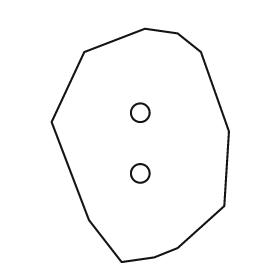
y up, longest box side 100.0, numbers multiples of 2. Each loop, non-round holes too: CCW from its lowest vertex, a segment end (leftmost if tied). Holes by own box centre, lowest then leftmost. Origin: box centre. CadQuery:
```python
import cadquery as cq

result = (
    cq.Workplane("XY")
    .moveTo(-8.0, -50.0)
    .lineTo(6.0, -48.0)
    .lineTo(16.0, -44.0)
    .lineTo(36.0, -26.0)
    .lineTo(38.0, 6.0)
    .lineTo(26.0, 40.0)
    .lineTo(16.0, 48.0)
    .lineTo(2.0, 50.0)
    .lineTo(-24.0, 40.0)
    .lineTo(-38.0, 10.0)
    .lineTo(-22.0, -32.0)
    .close()
    .moveTo(0.0, -12.0)
    .circle(4.0)
    .moveTo(0.0, 14.0)
    .circle(4.0)
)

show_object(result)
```